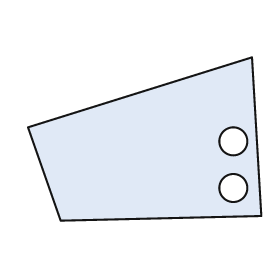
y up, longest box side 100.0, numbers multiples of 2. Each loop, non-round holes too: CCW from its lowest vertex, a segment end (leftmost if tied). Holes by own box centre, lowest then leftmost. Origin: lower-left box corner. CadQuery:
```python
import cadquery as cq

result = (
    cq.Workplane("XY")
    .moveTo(14.0, 0.0)
    .lineTo(100.0, 2.0)
    .lineTo(96.0, 70.0)
    .lineTo(0.0, 40.0)
    .close()
    .moveTo(88.0, 14.0)
    .circle(6.0)
    .moveTo(88.0, 34.0)
    .circle(6.0)
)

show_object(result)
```